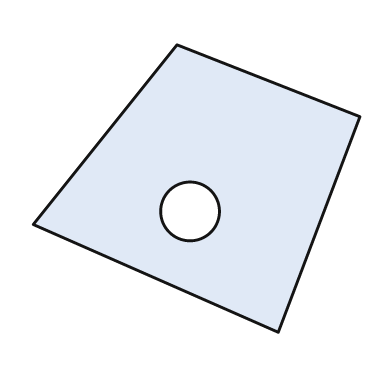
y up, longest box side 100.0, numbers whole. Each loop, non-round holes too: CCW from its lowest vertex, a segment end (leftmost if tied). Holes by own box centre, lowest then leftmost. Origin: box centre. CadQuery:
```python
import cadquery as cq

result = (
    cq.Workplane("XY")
    .moveTo(25.0, -44.0)
    .lineTo(50.0, 22.0)
    .lineTo(-6.0, 44.0)
    .lineTo(-50.0, -11.0)
    .close()
    .moveTo(-2.0, -7.0)
    .circle(9.0)
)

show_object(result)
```